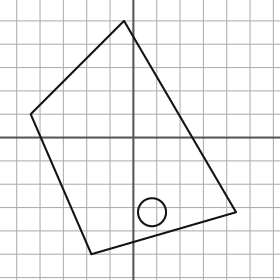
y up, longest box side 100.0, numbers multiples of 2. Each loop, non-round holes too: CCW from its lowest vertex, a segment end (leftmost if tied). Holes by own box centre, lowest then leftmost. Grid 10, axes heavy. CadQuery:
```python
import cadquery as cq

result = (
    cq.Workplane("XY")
    .moveTo(-18.0, -50.0)
    .lineTo(44.0, -32.0)
    .lineTo(-4.0, 50.0)
    .lineTo(-44.0, 10.0)
    .close()
    .moveTo(8.0, -32.0)
    .circle(6.0)
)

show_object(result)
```